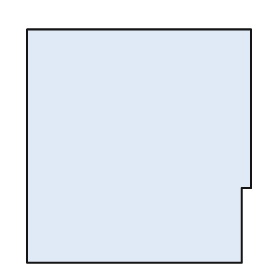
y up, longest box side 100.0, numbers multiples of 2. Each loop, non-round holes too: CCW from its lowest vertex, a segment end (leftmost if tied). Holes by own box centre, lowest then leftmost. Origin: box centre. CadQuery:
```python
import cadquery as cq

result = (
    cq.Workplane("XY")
    .moveTo(-48.0, -50.0)
    .lineTo(44.0, -50.0)
    .lineTo(44.0, -18.0)
    .lineTo(48.0, -18.0)
    .lineTo(48.0, 50.0)
    .lineTo(-48.0, 50.0)
    .close()
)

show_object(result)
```